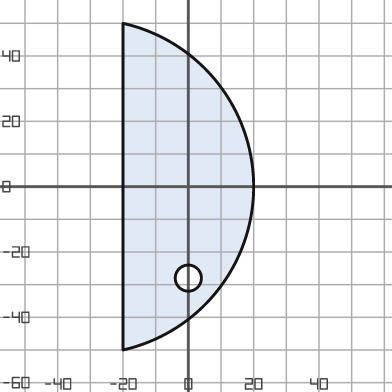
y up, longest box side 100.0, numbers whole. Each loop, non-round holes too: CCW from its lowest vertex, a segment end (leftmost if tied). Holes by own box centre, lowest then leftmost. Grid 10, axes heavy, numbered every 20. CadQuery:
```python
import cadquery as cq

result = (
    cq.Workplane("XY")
    .moveTo(-20.0, -50.0)
    .threePointArc((20.0, 0.0), (-20.0, 50.0))
    .close()
    .moveTo(0.0, -28.0)
    .circle(4.0)
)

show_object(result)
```